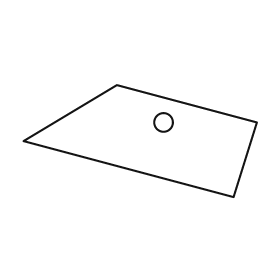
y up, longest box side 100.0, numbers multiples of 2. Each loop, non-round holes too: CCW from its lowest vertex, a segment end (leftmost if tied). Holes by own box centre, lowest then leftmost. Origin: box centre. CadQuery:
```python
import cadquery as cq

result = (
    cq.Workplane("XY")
    .moveTo(40.0, -24.0)
    .lineTo(50.0, 8.0)
    .lineTo(-10.0, 24.0)
    .lineTo(-50.0, 0.0)
    .close()
    .moveTo(10.0, 8.0)
    .circle(4.0)
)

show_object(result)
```